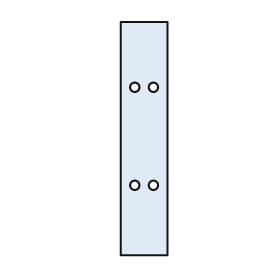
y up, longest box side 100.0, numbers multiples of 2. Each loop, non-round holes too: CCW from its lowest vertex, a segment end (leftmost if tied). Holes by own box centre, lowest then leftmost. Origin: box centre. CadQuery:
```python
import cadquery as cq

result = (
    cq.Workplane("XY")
    .moveTo(-10.0, -50.0)
    .lineTo(10.0, -50.0)
    .lineTo(10.0, 50.0)
    .lineTo(-10.0, 50.0)
    .close()
    .moveTo(-4.0, -20.0)
    .circle(2.0)
    .moveTo(4.0, -20.0)
    .circle(2.0)
    .moveTo(-4.0, 22.0)
    .circle(2.0)
    .moveTo(4.0, 22.0)
    .circle(2.0)
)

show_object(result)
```